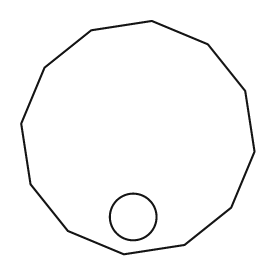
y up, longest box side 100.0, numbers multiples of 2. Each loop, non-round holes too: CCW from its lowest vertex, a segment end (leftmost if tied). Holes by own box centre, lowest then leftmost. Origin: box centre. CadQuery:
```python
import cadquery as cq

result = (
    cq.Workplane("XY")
    .moveTo(-6.0, -50.0)
    .lineTo(20.0, -46.0)
    .lineTo(40.0, -30.0)
    .lineTo(50.0, -6.0)
    .lineTo(46.0, 20.0)
    .lineTo(30.0, 40.0)
    .lineTo(6.0, 50.0)
    .lineTo(-20.0, 46.0)
    .lineTo(-40.0, 30.0)
    .lineTo(-50.0, 6.0)
    .lineTo(-46.0, -20.0)
    .lineTo(-30.0, -40.0)
    .close()
    .moveTo(-2.0, -34.0)
    .circle(10.0)
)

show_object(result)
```